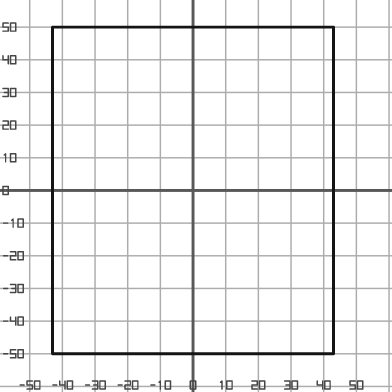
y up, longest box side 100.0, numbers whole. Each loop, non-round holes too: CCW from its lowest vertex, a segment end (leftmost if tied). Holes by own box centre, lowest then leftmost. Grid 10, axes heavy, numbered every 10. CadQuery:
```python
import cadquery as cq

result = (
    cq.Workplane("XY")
    .moveTo(-43.0, -50.0)
    .lineTo(43.0, -50.0)
    .lineTo(43.0, 50.0)
    .lineTo(-43.0, 50.0)
    .close()
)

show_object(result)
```